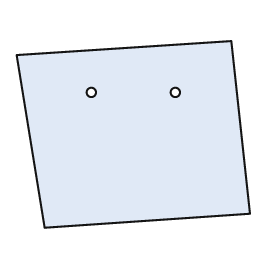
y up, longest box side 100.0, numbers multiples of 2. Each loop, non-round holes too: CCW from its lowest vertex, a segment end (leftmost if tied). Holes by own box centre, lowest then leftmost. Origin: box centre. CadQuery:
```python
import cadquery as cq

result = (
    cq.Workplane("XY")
    .moveTo(-38.0, -40.0)
    .lineTo(50.0, -34.0)
    .lineTo(42.0, 40.0)
    .lineTo(-50.0, 34.0)
    .close()
    .moveTo(-18.0, 18.0)
    .circle(2.0)
    .moveTo(18.0, 18.0)
    .circle(2.0)
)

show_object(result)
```